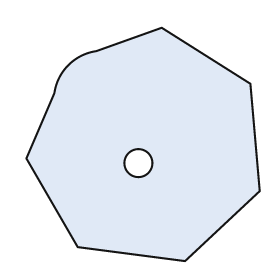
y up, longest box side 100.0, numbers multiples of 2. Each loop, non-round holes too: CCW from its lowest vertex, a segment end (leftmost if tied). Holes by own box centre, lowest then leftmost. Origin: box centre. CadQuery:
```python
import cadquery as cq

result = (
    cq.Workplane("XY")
    .moveTo(18.0, -50.0)
    .lineTo(50.0, -20.0)
    .lineTo(46.0, 26.0)
    .lineTo(8.0, 50.0)
    .lineTo(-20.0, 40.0)
    .threePointArc((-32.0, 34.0), (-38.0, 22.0))
    .lineTo(-50.0, -6.0)
    .lineTo(-28.0, -44.0)
    .close()
    .moveTo(-2.0, -8.0)
    .circle(6.0)
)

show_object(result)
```